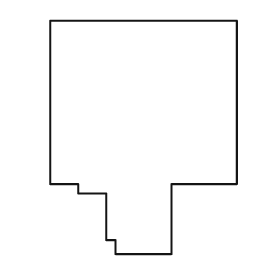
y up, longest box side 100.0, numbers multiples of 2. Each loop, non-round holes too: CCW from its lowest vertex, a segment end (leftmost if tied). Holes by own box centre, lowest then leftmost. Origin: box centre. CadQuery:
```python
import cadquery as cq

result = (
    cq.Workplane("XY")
    .moveTo(-12.0, -50.0)
    .lineTo(12.0, -50.0)
    .lineTo(12.0, -20.0)
    .lineTo(40.0, -20.0)
    .lineTo(40.0, 50.0)
    .lineTo(-40.0, 50.0)
    .lineTo(-40.0, -20.0)
    .lineTo(-28.0, -20.0)
    .lineTo(-28.0, -24.0)
    .lineTo(-16.0, -24.0)
    .lineTo(-16.0, -44.0)
    .lineTo(-12.0, -44.0)
    .close()
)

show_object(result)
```